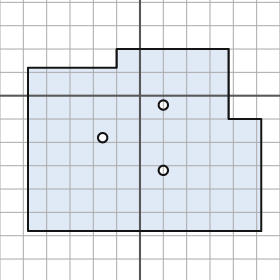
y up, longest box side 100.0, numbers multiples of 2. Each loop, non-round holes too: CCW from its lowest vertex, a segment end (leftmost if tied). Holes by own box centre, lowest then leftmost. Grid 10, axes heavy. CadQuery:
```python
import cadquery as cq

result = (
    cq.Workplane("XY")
    .moveTo(-48.0, -58.0)
    .lineTo(52.0, -58.0)
    .lineTo(52.0, -10.0)
    .lineTo(38.0, -10.0)
    .lineTo(38.0, 20.0)
    .lineTo(-10.0, 20.0)
    .lineTo(-10.0, 12.0)
    .lineTo(-48.0, 12.0)
    .close()
    .moveTo(10.0, -32.0)
    .circle(2.0)
    .moveTo(-16.0, -18.0)
    .circle(2.0)
    .moveTo(10.0, -4.0)
    .circle(2.0)
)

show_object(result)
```